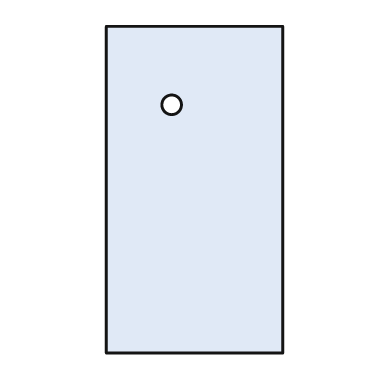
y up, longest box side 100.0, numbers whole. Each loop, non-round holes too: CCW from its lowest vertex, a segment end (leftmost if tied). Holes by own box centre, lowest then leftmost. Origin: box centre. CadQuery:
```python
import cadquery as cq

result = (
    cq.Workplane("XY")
    .moveTo(-27.0, -50.0)
    .lineTo(27.0, -50.0)
    .lineTo(27.0, 50.0)
    .lineTo(-27.0, 50.0)
    .close()
    .moveTo(-7.0, 26.0)
    .circle(3.0)
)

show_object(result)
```